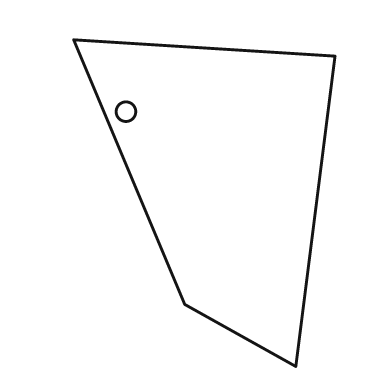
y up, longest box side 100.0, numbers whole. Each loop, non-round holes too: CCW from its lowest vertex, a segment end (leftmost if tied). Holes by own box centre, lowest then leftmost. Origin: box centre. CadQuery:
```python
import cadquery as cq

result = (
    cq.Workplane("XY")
    .moveTo(28.0, -50.0)
    .lineTo(40.0, 45.0)
    .lineTo(-40.0, 50.0)
    .lineTo(-6.0, -31.0)
    .close()
    .moveTo(-24.0, 28.0)
    .circle(3.0)
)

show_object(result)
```